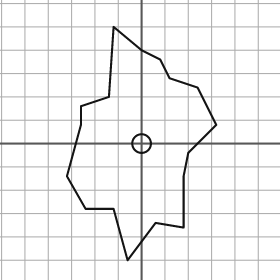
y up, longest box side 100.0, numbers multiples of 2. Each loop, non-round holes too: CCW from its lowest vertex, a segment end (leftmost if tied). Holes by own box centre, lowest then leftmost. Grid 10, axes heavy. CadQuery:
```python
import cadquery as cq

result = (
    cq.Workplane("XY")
    .moveTo(-6.0, -50.0)
    .lineTo(6.0, -34.0)
    .lineTo(18.0, -36.0)
    .lineTo(18.0, -14.0)
    .lineTo(20.0, -4.0)
    .lineTo(32.0, 8.0)
    .lineTo(24.0, 24.0)
    .lineTo(12.0, 28.0)
    .lineTo(8.0, 36.0)
    .lineTo(0.0, 40.0)
    .lineTo(-12.0, 50.0)
    .lineTo(-14.0, 20.0)
    .lineTo(-26.0, 16.0)
    .lineTo(-26.0, 8.0)
    .lineTo(-32.0, -14.0)
    .lineTo(-24.0, -28.0)
    .lineTo(-12.0, -28.0)
    .close()
    .moveTo(0.0, 0.0)
    .circle(4.0)
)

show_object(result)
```